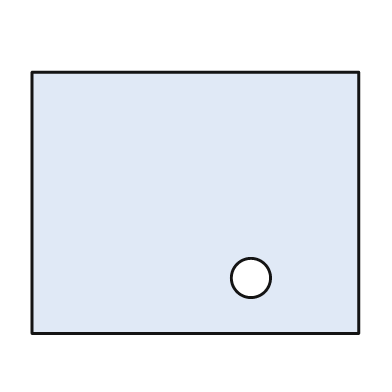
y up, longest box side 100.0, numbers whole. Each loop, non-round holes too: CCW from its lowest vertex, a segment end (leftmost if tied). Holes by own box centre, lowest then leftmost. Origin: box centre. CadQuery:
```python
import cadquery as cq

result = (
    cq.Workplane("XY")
    .moveTo(-50.0, -40.0)
    .lineTo(50.0, -40.0)
    .lineTo(50.0, 40.0)
    .lineTo(-50.0, 40.0)
    .close()
    .moveTo(17.0, -23.0)
    .circle(6.0)
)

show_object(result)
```